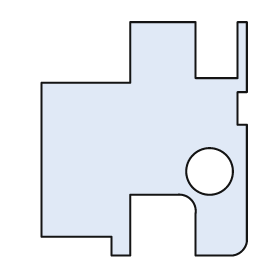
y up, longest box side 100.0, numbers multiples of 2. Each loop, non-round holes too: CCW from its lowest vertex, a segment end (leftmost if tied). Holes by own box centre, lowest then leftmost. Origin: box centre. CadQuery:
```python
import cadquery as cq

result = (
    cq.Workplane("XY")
    .moveTo(-14.0, -50.0)
    .lineTo(-6.0, -50.0)
    .lineTo(-6.0, -24.0)
    .lineTo(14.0, -24.0)
    .threePointArc((20.0, -26.0), (22.0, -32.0))
    .lineTo(22.0, -50.0)
    .lineTo(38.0, -50.0)
    .threePointArc((42.0, -48.0), (44.0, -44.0))
    .lineTo(44.0, 6.0)
    .lineTo(40.0, 6.0)
    .lineTo(40.0, 20.0)
    .lineTo(44.0, 20.0)
    .lineTo(44.0, 50.0)
    .lineTo(40.0, 50.0)
    .lineTo(40.0, 26.0)
    .lineTo(22.0, 26.0)
    .lineTo(22.0, 50.0)
    .lineTo(-6.0, 50.0)
    .lineTo(-6.0, 24.0)
    .lineTo(-44.0, 24.0)
    .lineTo(-44.0, -42.0)
    .lineTo(-14.0, -42.0)
    .close()
    .moveTo(28.0, -14.0)
    .circle(10.0)
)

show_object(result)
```